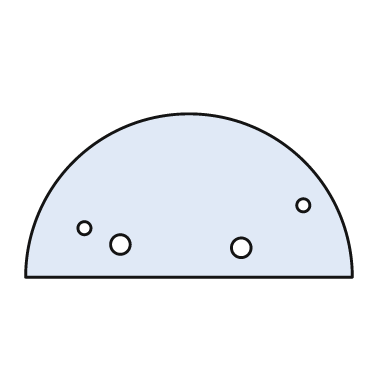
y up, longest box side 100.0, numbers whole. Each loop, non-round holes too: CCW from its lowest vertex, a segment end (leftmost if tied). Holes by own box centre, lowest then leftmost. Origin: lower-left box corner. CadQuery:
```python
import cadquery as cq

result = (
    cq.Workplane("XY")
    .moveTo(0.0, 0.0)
    .lineTo(100.0, 0.0)
    .threePointArc((50.0, 50.0), (0.0, 0.0))
    .close()
    .moveTo(66.0, 9.0)
    .circle(3.0)
    .moveTo(29.0, 10.0)
    .circle(3.0)
    .moveTo(18.0, 15.0)
    .circle(2.0)
    .moveTo(85.0, 22.0)
    .circle(2.0)
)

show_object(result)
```